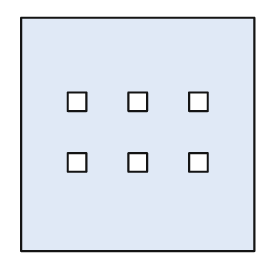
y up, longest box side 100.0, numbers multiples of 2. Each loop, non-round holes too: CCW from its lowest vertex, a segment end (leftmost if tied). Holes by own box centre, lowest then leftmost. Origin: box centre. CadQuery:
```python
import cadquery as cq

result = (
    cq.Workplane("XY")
    .moveTo(-50.0, -50.0)
    .lineTo(50.0, -50.0)
    .lineTo(50.0, 50.0)
    .lineTo(-50.0, 50.0)
    .close()
    .moveTo(-30.0, -16.0)
    .lineTo(-22.0, -16.0)
    .lineTo(-22.0, -8.0)
    .lineTo(-30.0, -8.0)
    .close()
    .moveTo(-4.0, -16.0)
    .lineTo(4.0, -16.0)
    .lineTo(4.0, -8.0)
    .lineTo(-4.0, -8.0)
    .close()
    .moveTo(22.0, -16.0)
    .lineTo(30.0, -16.0)
    .lineTo(30.0, -8.0)
    .lineTo(22.0, -8.0)
    .close()
    .moveTo(-30.0, 10.0)
    .lineTo(-22.0, 10.0)
    .lineTo(-22.0, 18.0)
    .lineTo(-30.0, 18.0)
    .close()
    .moveTo(-4.0, 10.0)
    .lineTo(4.0, 10.0)
    .lineTo(4.0, 18.0)
    .lineTo(-4.0, 18.0)
    .close()
    .moveTo(22.0, 10.0)
    .lineTo(30.0, 10.0)
    .lineTo(30.0, 18.0)
    .lineTo(22.0, 18.0)
    .close()
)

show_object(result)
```